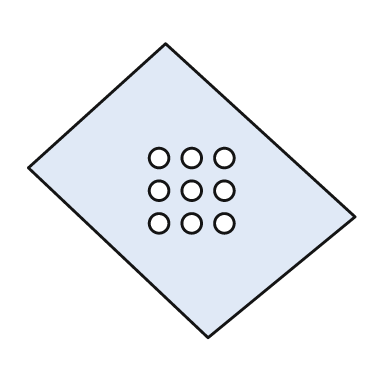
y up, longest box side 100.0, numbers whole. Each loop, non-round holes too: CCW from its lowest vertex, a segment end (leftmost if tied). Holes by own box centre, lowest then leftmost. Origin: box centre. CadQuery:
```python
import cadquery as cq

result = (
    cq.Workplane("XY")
    .moveTo(5.0, -45.0)
    .lineTo(50.0, -8.0)
    .lineTo(-8.0, 45.0)
    .lineTo(-50.0, 7.0)
    .close()
    .moveTo(-10.0, -10.0)
    .circle(3.0)
    .moveTo(0.0, -10.0)
    .circle(3.0)
    .moveTo(10.0, -10.0)
    .circle(3.0)
    .moveTo(-10.0, 0.0)
    .circle(3.0)
    .moveTo(0.0, 0.0)
    .circle(3.0)
    .moveTo(10.0, 0.0)
    .circle(3.0)
    .moveTo(-10.0, 10.0)
    .circle(3.0)
    .moveTo(0.0, 10.0)
    .circle(3.0)
    .moveTo(10.0, 10.0)
    .circle(3.0)
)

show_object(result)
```